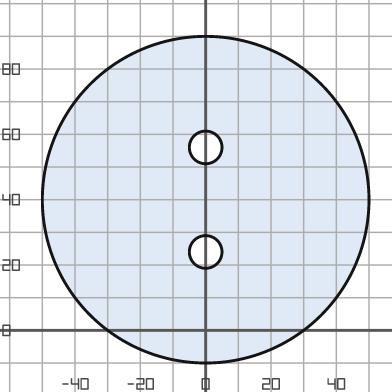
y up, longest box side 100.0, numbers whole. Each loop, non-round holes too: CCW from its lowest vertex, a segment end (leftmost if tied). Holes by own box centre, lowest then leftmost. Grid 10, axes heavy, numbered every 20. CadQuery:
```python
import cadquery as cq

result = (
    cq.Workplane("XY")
    .moveTo(0.0, 40.0)
    .circle(50.0)
    .moveTo(0.0, 24.0)
    .circle(5.0)
    .moveTo(0.0, 56.0)
    .circle(5.0)
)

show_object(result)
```